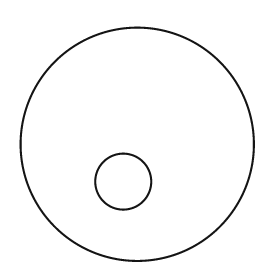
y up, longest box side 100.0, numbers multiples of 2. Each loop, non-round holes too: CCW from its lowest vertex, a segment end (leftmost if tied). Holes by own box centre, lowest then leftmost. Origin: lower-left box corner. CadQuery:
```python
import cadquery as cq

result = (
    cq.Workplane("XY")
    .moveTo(50.0, 50.0)
    .circle(50.0)
    .moveTo(44.0, 34.0)
    .circle(12.0)
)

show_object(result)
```